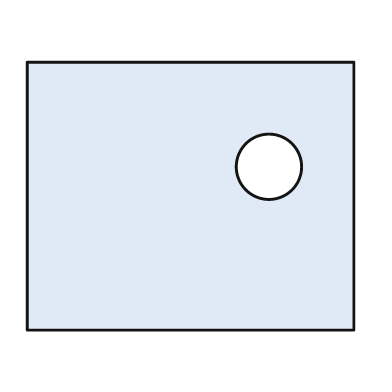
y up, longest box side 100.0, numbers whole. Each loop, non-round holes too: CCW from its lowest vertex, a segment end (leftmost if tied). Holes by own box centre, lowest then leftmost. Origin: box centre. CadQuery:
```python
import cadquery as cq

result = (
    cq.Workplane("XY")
    .moveTo(-50.0, -41.0)
    .lineTo(50.0, -41.0)
    .lineTo(50.0, 41.0)
    .lineTo(-50.0, 41.0)
    .close()
    .moveTo(24.0, 9.0)
    .circle(10.0)
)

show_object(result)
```